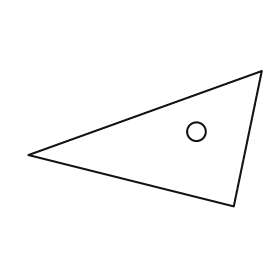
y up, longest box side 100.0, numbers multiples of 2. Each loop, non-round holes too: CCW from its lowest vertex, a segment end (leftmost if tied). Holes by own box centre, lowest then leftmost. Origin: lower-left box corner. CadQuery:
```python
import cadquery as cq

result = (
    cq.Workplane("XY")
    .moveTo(88.0, 0.0)
    .lineTo(100.0, 58.0)
    .lineTo(0.0, 22.0)
    .close()
    .moveTo(72.0, 32.0)
    .circle(4.0)
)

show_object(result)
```